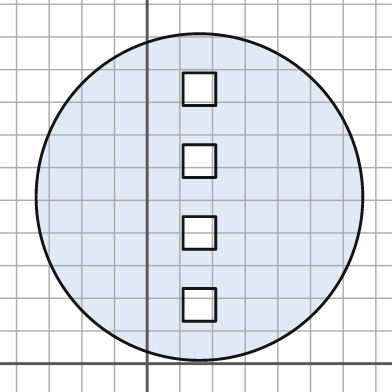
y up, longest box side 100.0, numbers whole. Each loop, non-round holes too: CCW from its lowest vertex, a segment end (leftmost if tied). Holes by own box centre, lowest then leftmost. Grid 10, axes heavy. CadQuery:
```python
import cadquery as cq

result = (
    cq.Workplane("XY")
    .moveTo(16.0, 51.0)
    .circle(50.0)
    .moveTo(11.0, 13.0)
    .lineTo(21.0, 13.0)
    .lineTo(21.0, 23.0)
    .lineTo(11.0, 23.0)
    .close()
    .moveTo(11.0, 35.0)
    .lineTo(21.0, 35.0)
    .lineTo(21.0, 45.0)
    .lineTo(11.0, 45.0)
    .close()
    .moveTo(11.0, 57.0)
    .lineTo(21.0, 57.0)
    .lineTo(21.0, 67.0)
    .lineTo(11.0, 67.0)
    .close()
    .moveTo(11.0, 79.0)
    .lineTo(21.0, 79.0)
    .lineTo(21.0, 89.0)
    .lineTo(11.0, 89.0)
    .close()
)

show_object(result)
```